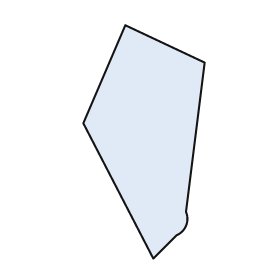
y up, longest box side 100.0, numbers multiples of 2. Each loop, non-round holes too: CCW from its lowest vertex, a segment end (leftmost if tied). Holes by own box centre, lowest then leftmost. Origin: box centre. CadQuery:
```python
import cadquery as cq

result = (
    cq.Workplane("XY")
    .moveTo(4.0, -50.0)
    .lineTo(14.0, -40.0)
    .threePointArc((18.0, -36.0), (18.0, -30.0))
    .lineTo(26.0, 34.0)
    .lineTo(-8.0, 50.0)
    .lineTo(-26.0, 8.0)
    .close()
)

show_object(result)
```